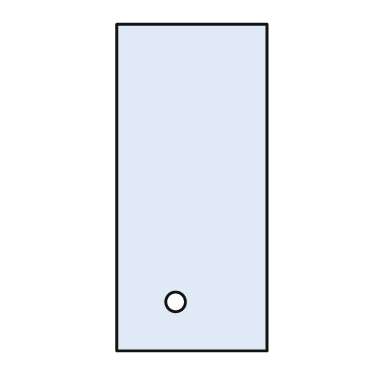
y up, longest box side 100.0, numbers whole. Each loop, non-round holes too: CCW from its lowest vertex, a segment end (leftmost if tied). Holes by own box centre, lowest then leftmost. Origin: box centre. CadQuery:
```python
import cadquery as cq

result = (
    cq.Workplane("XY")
    .moveTo(-23.0, -50.0)
    .lineTo(23.0, -50.0)
    .lineTo(23.0, 50.0)
    .lineTo(-23.0, 50.0)
    .close()
    .moveTo(-5.0, -35.0)
    .circle(3.0)
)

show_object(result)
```